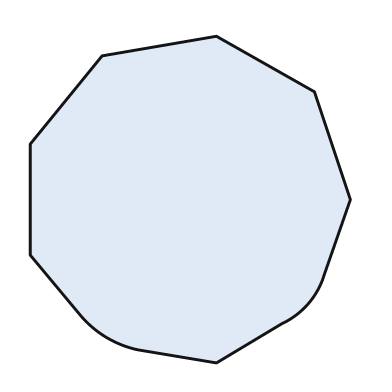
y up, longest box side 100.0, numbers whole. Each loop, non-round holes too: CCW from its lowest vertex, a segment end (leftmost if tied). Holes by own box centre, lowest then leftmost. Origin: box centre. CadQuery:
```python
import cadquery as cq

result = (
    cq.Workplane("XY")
    .moveTo(8.0, -50.0)
    .lineTo(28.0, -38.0)
    .threePointArc((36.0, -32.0), (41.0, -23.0))
    .lineTo(49.0, 0.0)
    .lineTo(38.0, 33.0)
    .lineTo(8.0, 50.0)
    .lineTo(-27.0, 44.0)
    .lineTo(-49.0, 17.0)
    .lineTo(-49.0, -17.0)
    .lineTo(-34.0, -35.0)
    .threePointArc((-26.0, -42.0), (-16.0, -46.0))
    .close()
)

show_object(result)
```